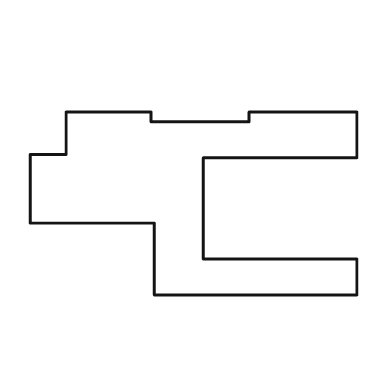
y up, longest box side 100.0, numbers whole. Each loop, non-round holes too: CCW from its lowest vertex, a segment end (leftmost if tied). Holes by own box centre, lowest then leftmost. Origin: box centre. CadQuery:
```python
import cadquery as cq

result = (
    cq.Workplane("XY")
    .moveTo(-12.0, -28.0)
    .lineTo(50.0, -28.0)
    .lineTo(50.0, -17.0)
    .lineTo(3.0, -17.0)
    .lineTo(3.0, 14.0)
    .lineTo(50.0, 14.0)
    .lineTo(50.0, 28.0)
    .lineTo(17.0, 28.0)
    .lineTo(17.0, 25.0)
    .lineTo(-13.0, 25.0)
    .lineTo(-13.0, 28.0)
    .lineTo(-39.0, 28.0)
    .lineTo(-39.0, 15.0)
    .lineTo(-50.0, 15.0)
    .lineTo(-50.0, -6.0)
    .lineTo(-12.0, -6.0)
    .close()
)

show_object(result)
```